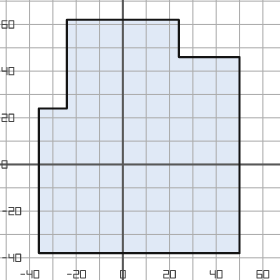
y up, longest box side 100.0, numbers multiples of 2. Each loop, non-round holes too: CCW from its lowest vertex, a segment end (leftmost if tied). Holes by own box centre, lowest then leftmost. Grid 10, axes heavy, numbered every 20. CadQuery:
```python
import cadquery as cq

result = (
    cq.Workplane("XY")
    .moveTo(-36.0, -38.0)
    .lineTo(50.0, -38.0)
    .lineTo(50.0, 46.0)
    .lineTo(24.0, 46.0)
    .lineTo(24.0, 62.0)
    .lineTo(-24.0, 62.0)
    .lineTo(-24.0, 24.0)
    .lineTo(-36.0, 24.0)
    .close()
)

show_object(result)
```